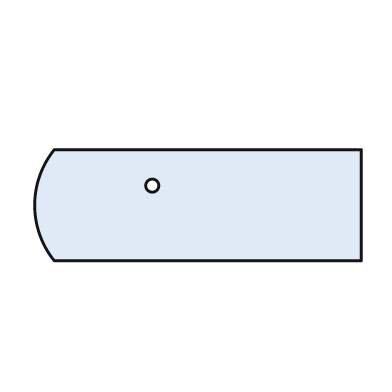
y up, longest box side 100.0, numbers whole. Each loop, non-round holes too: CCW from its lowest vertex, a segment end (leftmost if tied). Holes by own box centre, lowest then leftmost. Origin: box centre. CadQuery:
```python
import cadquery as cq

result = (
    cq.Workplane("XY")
    .moveTo(-44.0, -17.0)
    .lineTo(50.0, -17.0)
    .lineTo(50.0, 17.0)
    .lineTo(-44.0, 17.0)
    .threePointArc((-50.0, 0.0), (-44.0, -17.0))
    .close()
    .moveTo(-14.0, 6.0)
    .circle(2.0)
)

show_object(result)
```